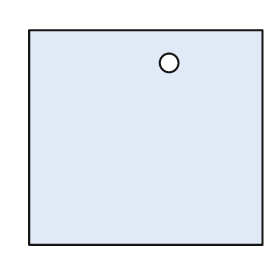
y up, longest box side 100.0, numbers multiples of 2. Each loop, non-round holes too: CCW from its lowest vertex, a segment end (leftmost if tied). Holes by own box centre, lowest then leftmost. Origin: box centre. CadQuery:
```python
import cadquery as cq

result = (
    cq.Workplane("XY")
    .moveTo(-50.0, -46.0)
    .lineTo(50.0, -46.0)
    .lineTo(50.0, 46.0)
    .lineTo(-50.0, 46.0)
    .close()
    .moveTo(10.0, 32.0)
    .circle(4.0)
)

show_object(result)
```